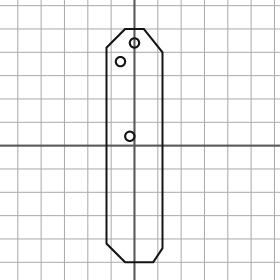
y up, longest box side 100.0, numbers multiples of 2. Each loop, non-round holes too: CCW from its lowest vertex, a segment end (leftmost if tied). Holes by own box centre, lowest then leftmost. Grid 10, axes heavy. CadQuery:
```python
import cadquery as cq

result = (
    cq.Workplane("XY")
    .moveTo(-4.0, -50.0)
    .lineTo(8.0, -50.0)
    .lineTo(12.0, -44.0)
    .lineTo(12.0, 40.0)
    .lineTo(4.0, 50.0)
    .lineTo(-4.0, 50.0)
    .lineTo(-12.0, 42.0)
    .lineTo(-12.0, -42.0)
    .close()
    .moveTo(-2.0, 4.0)
    .circle(2.0)
    .moveTo(-6.0, 36.0)
    .circle(2.0)
    .moveTo(0.0, 44.0)
    .circle(2.0)
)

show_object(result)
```